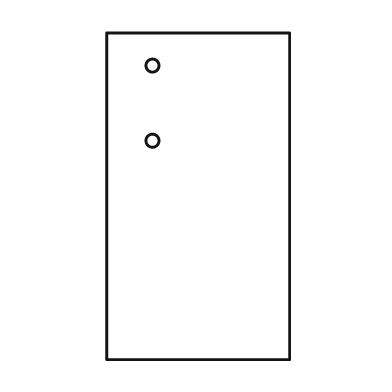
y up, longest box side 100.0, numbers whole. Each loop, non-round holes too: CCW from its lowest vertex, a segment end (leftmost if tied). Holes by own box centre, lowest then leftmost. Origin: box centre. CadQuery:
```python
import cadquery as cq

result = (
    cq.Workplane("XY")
    .moveTo(-28.0, -50.0)
    .lineTo(28.0, -50.0)
    .lineTo(28.0, 50.0)
    .lineTo(-28.0, 50.0)
    .close()
    .moveTo(-14.0, 17.0)
    .circle(2.0)
    .moveTo(-14.0, 40.0)
    .circle(2.0)
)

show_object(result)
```